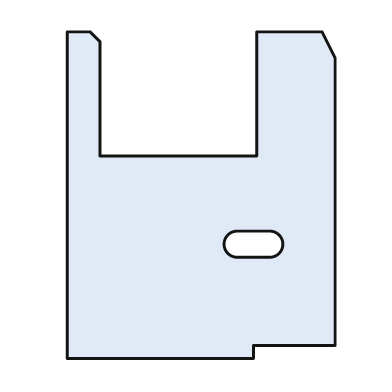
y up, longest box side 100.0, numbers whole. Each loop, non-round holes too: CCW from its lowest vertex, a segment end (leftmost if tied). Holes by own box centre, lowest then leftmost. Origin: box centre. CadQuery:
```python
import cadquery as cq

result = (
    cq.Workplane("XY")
    .moveTo(-41.0, -50.0)
    .lineTo(16.0, -50.0)
    .lineTo(16.0, -46.0)
    .lineTo(41.0, -46.0)
    .lineTo(41.0, 42.0)
    .lineTo(37.0, 50.0)
    .lineTo(17.0, 50.0)
    .lineTo(17.0, 12.0)
    .lineTo(-31.0, 12.0)
    .lineTo(-31.0, 47.0)
    .lineTo(-34.0, 50.0)
    .lineTo(-41.0, 50.0)
    .close()
    .moveTo(11.0, -19.0)
    .lineTo(21.0, -19.0)
    .threePointArc((25.0, -15.0), (21.0, -11.0))
    .lineTo(11.0, -11.0)
    .threePointArc((7.0, -15.0), (11.0, -19.0))
    .close()
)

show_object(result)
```